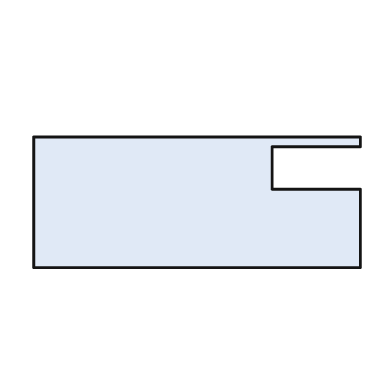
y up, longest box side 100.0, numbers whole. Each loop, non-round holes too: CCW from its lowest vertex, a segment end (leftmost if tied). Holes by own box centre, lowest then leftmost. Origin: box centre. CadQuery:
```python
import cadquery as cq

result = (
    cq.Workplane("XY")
    .moveTo(-50.0, -20.0)
    .lineTo(50.0, -20.0)
    .lineTo(50.0, 4.0)
    .lineTo(23.0, 4.0)
    .lineTo(23.0, 17.0)
    .lineTo(50.0, 17.0)
    .lineTo(50.0, 20.0)
    .lineTo(-50.0, 20.0)
    .close()
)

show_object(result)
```